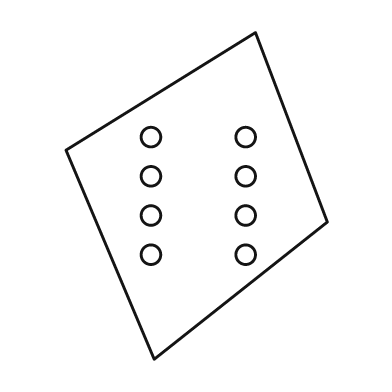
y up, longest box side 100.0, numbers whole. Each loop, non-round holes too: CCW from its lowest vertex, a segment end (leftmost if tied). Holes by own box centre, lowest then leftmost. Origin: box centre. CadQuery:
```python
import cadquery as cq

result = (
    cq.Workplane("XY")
    .moveTo(-13.0, -50.0)
    .lineTo(40.0, -8.0)
    .lineTo(18.0, 50.0)
    .lineTo(-40.0, 14.0)
    .close()
    .moveTo(-14.0, -18.0)
    .circle(3.0)
    .moveTo(15.0, -18.0)
    .circle(3.0)
    .moveTo(-14.0, -6.0)
    .circle(3.0)
    .moveTo(15.0, -6.0)
    .circle(3.0)
    .moveTo(-14.0, 6.0)
    .circle(3.0)
    .moveTo(15.0, 6.0)
    .circle(3.0)
    .moveTo(-14.0, 18.0)
    .circle(3.0)
    .moveTo(15.0, 18.0)
    .circle(3.0)
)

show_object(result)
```